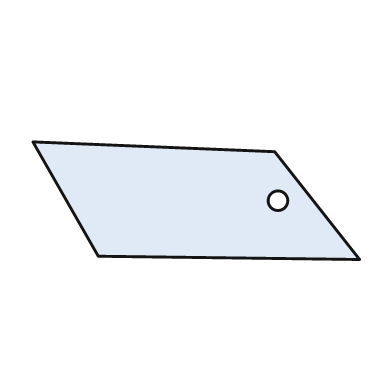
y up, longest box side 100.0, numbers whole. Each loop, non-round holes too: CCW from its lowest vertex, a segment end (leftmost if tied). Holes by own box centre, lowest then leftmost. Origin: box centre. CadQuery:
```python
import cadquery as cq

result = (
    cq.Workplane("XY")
    .moveTo(50.0, -18.0)
    .lineTo(24.0, 15.0)
    .lineTo(-50.0, 18.0)
    .lineTo(-30.0, -17.0)
    .close()
    .moveTo(25.0, 0.0)
    .circle(3.0)
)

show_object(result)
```